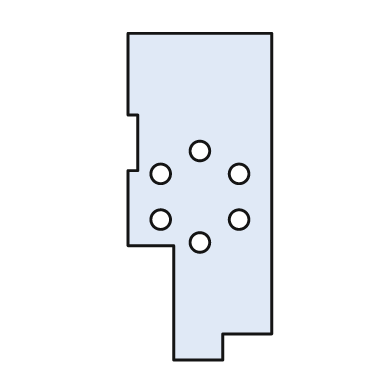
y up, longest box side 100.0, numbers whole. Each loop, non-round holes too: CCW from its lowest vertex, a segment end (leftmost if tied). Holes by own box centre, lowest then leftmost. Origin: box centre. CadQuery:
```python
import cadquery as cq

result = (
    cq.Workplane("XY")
    .moveTo(-8.0, -50.0)
    .lineTo(7.0, -50.0)
    .lineTo(7.0, -42.0)
    .lineTo(22.0, -42.0)
    .lineTo(22.0, 50.0)
    .lineTo(-22.0, 50.0)
    .lineTo(-22.0, 25.0)
    .lineTo(-19.0, 25.0)
    .lineTo(-19.0, 8.0)
    .lineTo(-22.0, 8.0)
    .lineTo(-22.0, -15.0)
    .lineTo(-8.0, -15.0)
    .close()
    .moveTo(0.0, -14.0)
    .circle(3.0)
    .moveTo(-12.0, -7.0)
    .circle(3.0)
    .moveTo(12.0, -7.0)
    .circle(3.0)
    .moveTo(-12.0, 7.0)
    .circle(3.0)
    .moveTo(12.0, 7.0)
    .circle(3.0)
    .moveTo(0.0, 14.0)
    .circle(3.0)
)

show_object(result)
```